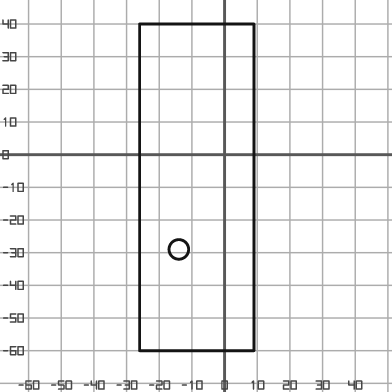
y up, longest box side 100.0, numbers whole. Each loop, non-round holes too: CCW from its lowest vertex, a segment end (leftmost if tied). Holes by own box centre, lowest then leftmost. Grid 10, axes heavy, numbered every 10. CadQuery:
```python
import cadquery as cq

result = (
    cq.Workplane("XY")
    .moveTo(-26.0, -60.0)
    .lineTo(9.0, -60.0)
    .lineTo(9.0, 40.0)
    .lineTo(-26.0, 40.0)
    .close()
    .moveTo(-14.0, -29.0)
    .circle(3.0)
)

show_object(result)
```